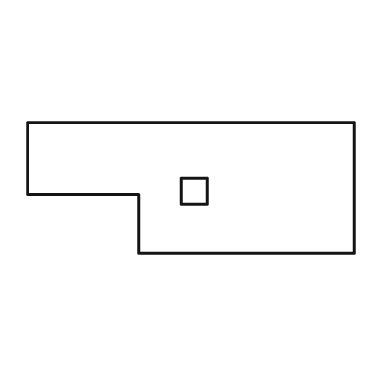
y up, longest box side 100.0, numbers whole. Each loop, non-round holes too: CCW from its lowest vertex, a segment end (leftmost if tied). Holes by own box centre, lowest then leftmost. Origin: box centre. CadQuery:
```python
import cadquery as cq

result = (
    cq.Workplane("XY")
    .moveTo(-16.0, -20.0)
    .lineTo(50.0, -20.0)
    .lineTo(50.0, 20.0)
    .lineTo(-50.0, 20.0)
    .lineTo(-50.0, -2.0)
    .lineTo(-16.0, -2.0)
    .close()
    .moveTo(-3.0, -5.0)
    .lineTo(5.0, -5.0)
    .lineTo(5.0, 3.0)
    .lineTo(-3.0, 3.0)
    .close()
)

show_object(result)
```